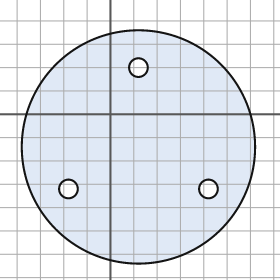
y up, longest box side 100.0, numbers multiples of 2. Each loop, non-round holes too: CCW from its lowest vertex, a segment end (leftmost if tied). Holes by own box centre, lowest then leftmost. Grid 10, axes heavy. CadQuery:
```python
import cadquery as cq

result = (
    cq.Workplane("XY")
    .moveTo(12.0, -14.0)
    .circle(50.0)
    .moveTo(-18.0, -32.0)
    .circle(4.0)
    .moveTo(42.0, -32.0)
    .circle(4.0)
    .moveTo(12.0, 20.0)
    .circle(4.0)
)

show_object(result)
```